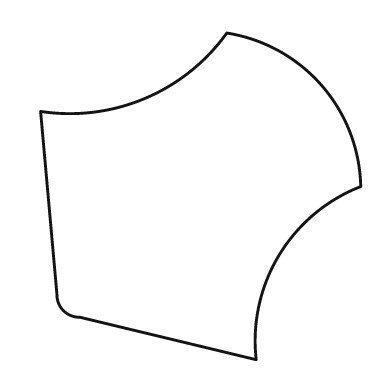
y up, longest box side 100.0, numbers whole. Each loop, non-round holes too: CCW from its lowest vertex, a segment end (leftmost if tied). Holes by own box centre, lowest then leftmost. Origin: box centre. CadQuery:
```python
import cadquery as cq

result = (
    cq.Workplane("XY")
    .moveTo(17.0, -50.0)
    .threePointArc((24.0, -18.0), (49.0, 3.0))
    .threePointArc((37.0, 34.0), (8.0, 50.0))
    .threePointArc((-17.0, 30.0), (-49.0, 26.0))
    .lineTo(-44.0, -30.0)
    .threePointArc((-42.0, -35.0), (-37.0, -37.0))
    .close()
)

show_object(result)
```